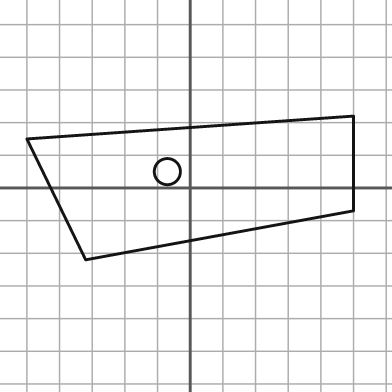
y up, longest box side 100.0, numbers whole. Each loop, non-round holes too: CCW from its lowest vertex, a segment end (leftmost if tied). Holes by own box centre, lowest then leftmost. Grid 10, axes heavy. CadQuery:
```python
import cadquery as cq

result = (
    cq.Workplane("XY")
    .moveTo(-32.0, -22.0)
    .lineTo(50.0, -7.0)
    .lineTo(50.0, 22.0)
    .lineTo(-50.0, 15.0)
    .close()
    .moveTo(-7.0, 5.0)
    .circle(4.0)
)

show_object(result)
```